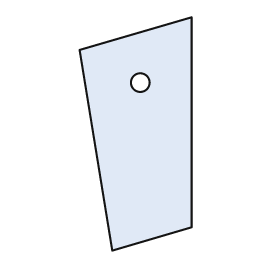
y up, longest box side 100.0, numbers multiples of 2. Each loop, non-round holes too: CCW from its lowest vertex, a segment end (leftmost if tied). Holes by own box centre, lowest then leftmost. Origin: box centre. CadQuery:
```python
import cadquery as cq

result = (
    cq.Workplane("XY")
    .moveTo(-10.0, -50.0)
    .lineTo(24.0, -40.0)
    .lineTo(24.0, 50.0)
    .lineTo(-24.0, 36.0)
    .close()
    .moveTo(2.0, 22.0)
    .circle(4.0)
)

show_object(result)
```